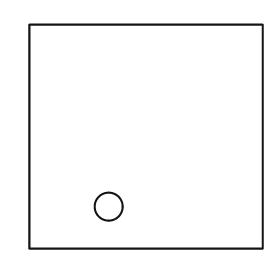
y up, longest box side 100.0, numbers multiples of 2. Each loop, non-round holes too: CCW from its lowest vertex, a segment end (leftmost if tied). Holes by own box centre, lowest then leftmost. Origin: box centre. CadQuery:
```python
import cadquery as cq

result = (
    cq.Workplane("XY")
    .moveTo(-50.0, -48.0)
    .lineTo(50.0, -48.0)
    .lineTo(50.0, 48.0)
    .lineTo(-50.0, 48.0)
    .close()
    .moveTo(-16.0, -30.0)
    .circle(6.0)
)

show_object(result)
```